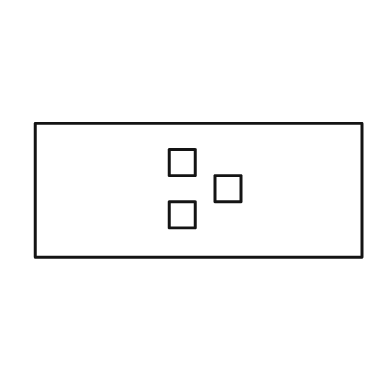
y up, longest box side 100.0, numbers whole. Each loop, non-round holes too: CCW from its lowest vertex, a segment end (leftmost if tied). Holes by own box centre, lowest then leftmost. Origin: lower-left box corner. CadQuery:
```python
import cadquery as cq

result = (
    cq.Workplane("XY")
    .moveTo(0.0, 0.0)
    .lineTo(100.0, 0.0)
    .lineTo(100.0, 41.0)
    .lineTo(0.0, 41.0)
    .close()
    .moveTo(41.0, 9.0)
    .lineTo(49.0, 9.0)
    .lineTo(49.0, 17.0)
    .lineTo(41.0, 17.0)
    .close()
    .moveTo(55.0, 17.0)
    .lineTo(63.0, 17.0)
    .lineTo(63.0, 25.0)
    .lineTo(55.0, 25.0)
    .close()
    .moveTo(41.0, 25.0)
    .lineTo(49.0, 25.0)
    .lineTo(49.0, 33.0)
    .lineTo(41.0, 33.0)
    .close()
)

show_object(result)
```